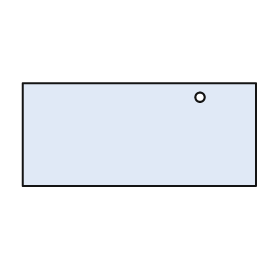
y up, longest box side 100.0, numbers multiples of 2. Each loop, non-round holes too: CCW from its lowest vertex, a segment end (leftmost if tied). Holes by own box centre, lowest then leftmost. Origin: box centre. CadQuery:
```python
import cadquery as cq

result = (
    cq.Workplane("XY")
    .moveTo(-50.0, -22.0)
    .lineTo(50.0, -22.0)
    .lineTo(50.0, 22.0)
    .lineTo(-50.0, 22.0)
    .close()
    .moveTo(26.0, 16.0)
    .circle(2.0)
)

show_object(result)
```